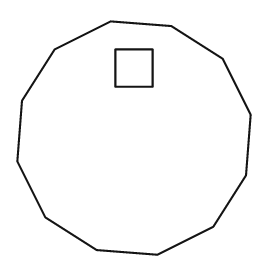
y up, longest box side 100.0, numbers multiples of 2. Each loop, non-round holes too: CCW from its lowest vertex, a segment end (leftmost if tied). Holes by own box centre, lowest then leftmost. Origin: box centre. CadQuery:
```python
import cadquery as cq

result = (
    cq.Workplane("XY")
    .moveTo(10.0, -50.0)
    .lineTo(34.0, -38.0)
    .lineTo(48.0, -16.0)
    .lineTo(50.0, 10.0)
    .lineTo(38.0, 34.0)
    .lineTo(16.0, 48.0)
    .lineTo(-10.0, 50.0)
    .lineTo(-34.0, 38.0)
    .lineTo(-48.0, 16.0)
    .lineTo(-50.0, -10.0)
    .lineTo(-38.0, -34.0)
    .lineTo(-16.0, -48.0)
    .close()
    .moveTo(-8.0, 22.0)
    .lineTo(8.0, 22.0)
    .lineTo(8.0, 38.0)
    .lineTo(-8.0, 38.0)
    .close()
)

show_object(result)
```